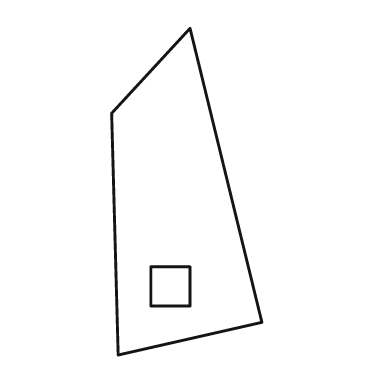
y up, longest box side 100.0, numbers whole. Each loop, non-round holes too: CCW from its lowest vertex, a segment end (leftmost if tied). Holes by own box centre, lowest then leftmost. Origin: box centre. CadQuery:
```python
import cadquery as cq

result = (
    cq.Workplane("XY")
    .moveTo(-21.0, -50.0)
    .lineTo(23.0, -40.0)
    .lineTo(1.0, 50.0)
    .lineTo(-23.0, 24.0)
    .close()
    .moveTo(-11.0, -35.0)
    .lineTo(1.0, -35.0)
    .lineTo(1.0, -23.0)
    .lineTo(-11.0, -23.0)
    .close()
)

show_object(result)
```